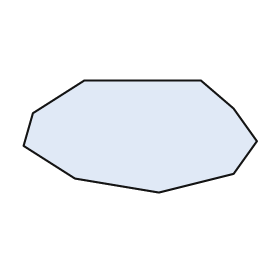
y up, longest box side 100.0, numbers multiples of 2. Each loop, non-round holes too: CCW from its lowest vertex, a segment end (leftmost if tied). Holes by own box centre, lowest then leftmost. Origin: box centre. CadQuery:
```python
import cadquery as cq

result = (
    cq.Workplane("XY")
    .moveTo(8.0, -24.0)
    .lineTo(40.0, -16.0)
    .lineTo(50.0, -2.0)
    .lineTo(40.0, 12.0)
    .lineTo(26.0, 24.0)
    .lineTo(-24.0, 24.0)
    .lineTo(-46.0, 10.0)
    .lineTo(-50.0, -4.0)
    .lineTo(-28.0, -18.0)
    .close()
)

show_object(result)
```